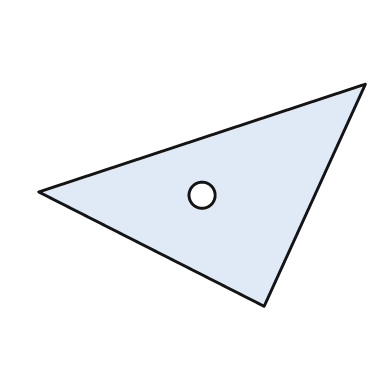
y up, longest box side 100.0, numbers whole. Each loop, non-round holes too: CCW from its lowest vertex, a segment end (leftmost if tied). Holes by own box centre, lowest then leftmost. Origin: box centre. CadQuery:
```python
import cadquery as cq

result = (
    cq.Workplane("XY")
    .moveTo(19.0, -34.0)
    .lineTo(50.0, 34.0)
    .lineTo(-50.0, 1.0)
    .close()
    .moveTo(0.0, 0.0)
    .circle(4.0)
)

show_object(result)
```